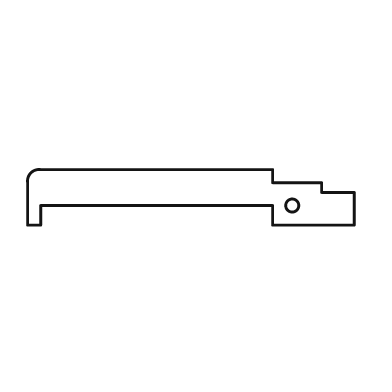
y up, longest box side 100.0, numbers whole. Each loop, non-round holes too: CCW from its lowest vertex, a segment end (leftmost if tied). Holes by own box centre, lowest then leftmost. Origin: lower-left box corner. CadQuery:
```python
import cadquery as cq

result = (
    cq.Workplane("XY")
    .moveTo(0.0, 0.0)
    .lineTo(4.0, 0.0)
    .lineTo(4.0, 6.0)
    .lineTo(75.0, 6.0)
    .lineTo(75.0, 0.0)
    .lineTo(100.0, 0.0)
    .lineTo(100.0, 10.0)
    .lineTo(90.0, 10.0)
    .lineTo(90.0, 13.0)
    .lineTo(75.0, 13.0)
    .lineTo(75.0, 17.0)
    .lineTo(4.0, 17.0)
    .threePointArc((1.0, 16.0), (0.0, 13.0))
    .close()
    .moveTo(81.0, 6.0)
    .circle(2.0)
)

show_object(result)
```